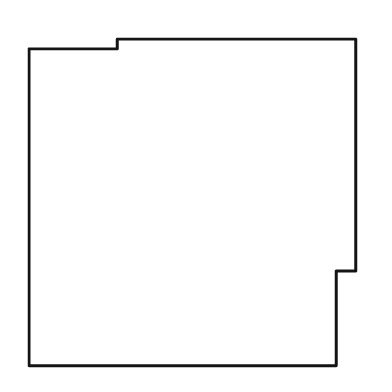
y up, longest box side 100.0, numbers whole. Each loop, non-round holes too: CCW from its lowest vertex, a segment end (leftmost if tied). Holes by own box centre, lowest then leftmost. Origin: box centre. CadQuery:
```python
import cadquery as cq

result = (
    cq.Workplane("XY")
    .moveTo(-50.0, -50.0)
    .lineTo(44.0, -50.0)
    .lineTo(44.0, -21.0)
    .lineTo(50.0, -21.0)
    .lineTo(50.0, 50.0)
    .lineTo(-23.0, 50.0)
    .lineTo(-23.0, 47.0)
    .lineTo(-50.0, 47.0)
    .close()
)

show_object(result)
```